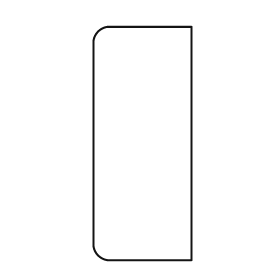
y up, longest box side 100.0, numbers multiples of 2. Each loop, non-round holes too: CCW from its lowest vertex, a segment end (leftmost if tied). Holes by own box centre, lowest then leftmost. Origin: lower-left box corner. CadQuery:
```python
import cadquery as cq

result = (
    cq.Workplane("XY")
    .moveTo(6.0, 0.0)
    .lineTo(42.0, 0.0)
    .lineTo(42.0, 100.0)
    .lineTo(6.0, 100.0)
    .threePointArc((2.0, 98.0), (0.0, 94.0))
    .lineTo(0.0, 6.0)
    .threePointArc((2.0, 2.0), (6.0, 0.0))
    .close()
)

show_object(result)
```